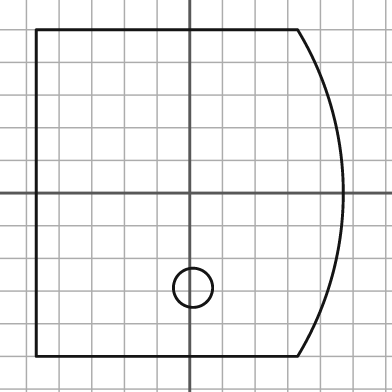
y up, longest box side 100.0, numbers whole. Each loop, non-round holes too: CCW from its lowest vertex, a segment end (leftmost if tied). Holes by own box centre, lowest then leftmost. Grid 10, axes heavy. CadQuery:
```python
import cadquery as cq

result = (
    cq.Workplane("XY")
    .moveTo(-47.0, -50.0)
    .lineTo(33.0, -50.0)
    .threePointArc((47.0, 0.0), (33.0, 50.0))
    .lineTo(-47.0, 50.0)
    .close()
    .moveTo(1.0, -29.0)
    .circle(6.0)
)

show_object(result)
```